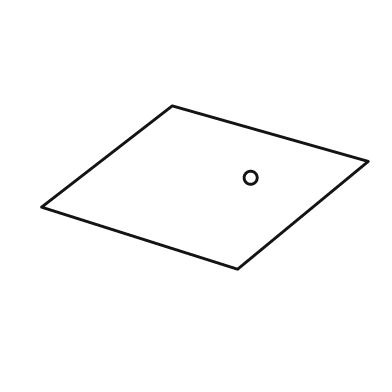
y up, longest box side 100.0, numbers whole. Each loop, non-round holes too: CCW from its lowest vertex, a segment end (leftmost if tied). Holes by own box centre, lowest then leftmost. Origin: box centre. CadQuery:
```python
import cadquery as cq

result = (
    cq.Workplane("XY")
    .moveTo(10.0, -25.0)
    .lineTo(50.0, 8.0)
    .lineTo(-10.0, 25.0)
    .lineTo(-50.0, -6.0)
    .close()
    .moveTo(14.0, 3.0)
    .circle(2.0)
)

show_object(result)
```